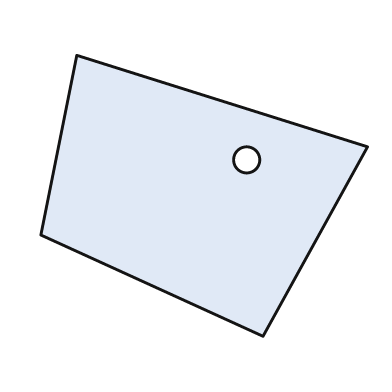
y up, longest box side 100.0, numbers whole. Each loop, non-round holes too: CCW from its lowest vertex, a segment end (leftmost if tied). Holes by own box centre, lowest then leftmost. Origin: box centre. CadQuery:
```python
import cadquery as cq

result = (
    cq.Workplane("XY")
    .moveTo(18.0, -43.0)
    .lineTo(50.0, 15.0)
    .lineTo(-39.0, 43.0)
    .lineTo(-50.0, -12.0)
    .close()
    .moveTo(13.0, 11.0)
    .circle(4.0)
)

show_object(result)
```